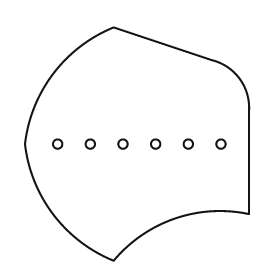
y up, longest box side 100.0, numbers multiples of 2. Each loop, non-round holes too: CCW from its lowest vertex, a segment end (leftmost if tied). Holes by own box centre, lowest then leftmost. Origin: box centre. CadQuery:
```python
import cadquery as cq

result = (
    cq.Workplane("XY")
    .moveTo(-10.0, -50.0)
    .threePointArc((16.0, -32.0), (48.0, -30.0))
    .lineTo(48.0, 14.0)
    .threePointArc((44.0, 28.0), (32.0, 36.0))
    .lineTo(-10.0, 50.0)
    .threePointArc((-36.0, 30.0), (-48.0, 0.0))
    .threePointArc((-36.0, -30.0), (-10.0, -50.0))
    .close()
    .moveTo(-34.0, 0.0)
    .circle(2.0)
    .moveTo(-20.0, 0.0)
    .circle(2.0)
    .moveTo(-6.0, 0.0)
    .circle(2.0)
    .moveTo(8.0, 0.0)
    .circle(2.0)
    .moveTo(22.0, 0.0)
    .circle(2.0)
    .moveTo(36.0, 0.0)
    .circle(2.0)
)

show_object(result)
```